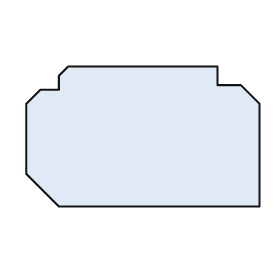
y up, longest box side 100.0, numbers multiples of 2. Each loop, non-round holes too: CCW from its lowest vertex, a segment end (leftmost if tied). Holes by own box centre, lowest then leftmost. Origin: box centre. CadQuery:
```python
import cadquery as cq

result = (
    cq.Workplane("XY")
    .moveTo(-36.0, -30.0)
    .lineTo(50.0, -30.0)
    .lineTo(50.0, 14.0)
    .lineTo(42.0, 22.0)
    .lineTo(32.0, 22.0)
    .lineTo(32.0, 30.0)
    .lineTo(-32.0, 30.0)
    .lineTo(-36.0, 26.0)
    .lineTo(-36.0, 20.0)
    .lineTo(-44.0, 20.0)
    .lineTo(-50.0, 14.0)
    .lineTo(-50.0, -16.0)
    .close()
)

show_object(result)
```